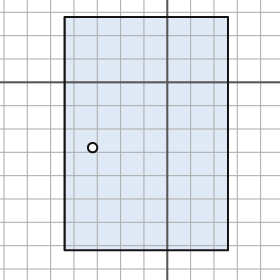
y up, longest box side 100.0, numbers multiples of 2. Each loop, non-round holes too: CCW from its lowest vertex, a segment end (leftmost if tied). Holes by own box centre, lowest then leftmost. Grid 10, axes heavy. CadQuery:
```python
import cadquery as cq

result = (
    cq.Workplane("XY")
    .moveTo(-44.0, -72.0)
    .lineTo(26.0, -72.0)
    .lineTo(26.0, 28.0)
    .lineTo(-44.0, 28.0)
    .close()
    .moveTo(-32.0, -28.0)
    .circle(2.0)
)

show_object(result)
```